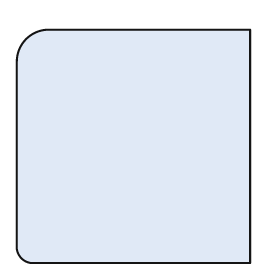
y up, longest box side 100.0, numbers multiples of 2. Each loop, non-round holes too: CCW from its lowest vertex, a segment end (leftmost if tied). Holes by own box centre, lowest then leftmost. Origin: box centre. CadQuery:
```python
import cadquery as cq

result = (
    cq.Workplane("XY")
    .moveTo(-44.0, -50.0)
    .lineTo(50.0, -50.0)
    .lineTo(50.0, 50.0)
    .lineTo(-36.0, 50.0)
    .threePointArc((-46.0, 46.0), (-50.0, 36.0))
    .lineTo(-50.0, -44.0)
    .threePointArc((-48.0, -48.0), (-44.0, -50.0))
    .close()
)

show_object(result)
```